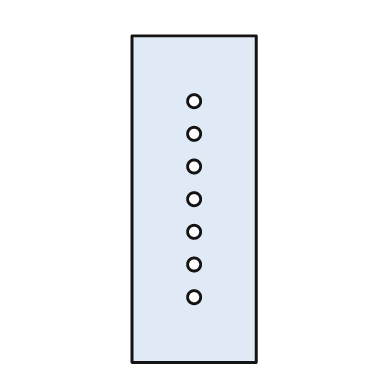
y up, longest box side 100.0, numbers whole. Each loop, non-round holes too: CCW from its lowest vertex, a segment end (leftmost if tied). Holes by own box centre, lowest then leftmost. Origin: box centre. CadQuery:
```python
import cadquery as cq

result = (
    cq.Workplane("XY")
    .moveTo(-19.0, -50.0)
    .lineTo(19.0, -50.0)
    .lineTo(19.0, 50.0)
    .lineTo(-19.0, 50.0)
    .close()
    .moveTo(0.0, -30.0)
    .circle(2.0)
    .moveTo(0.0, -20.0)
    .circle(2.0)
    .moveTo(0.0, -10.0)
    .circle(2.0)
    .moveTo(0.0, 0.0)
    .circle(2.0)
    .moveTo(0.0, 10.0)
    .circle(2.0)
    .moveTo(0.0, 20.0)
    .circle(2.0)
    .moveTo(0.0, 30.0)
    .circle(2.0)
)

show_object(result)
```